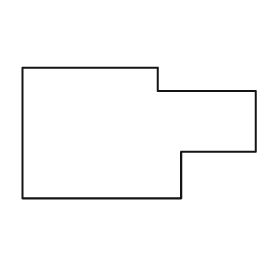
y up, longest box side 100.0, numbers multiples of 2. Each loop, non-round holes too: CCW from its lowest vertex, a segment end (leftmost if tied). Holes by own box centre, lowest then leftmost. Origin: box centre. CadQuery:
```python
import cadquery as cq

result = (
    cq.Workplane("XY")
    .moveTo(-50.0, -28.0)
    .lineTo(18.0, -28.0)
    .lineTo(18.0, -8.0)
    .lineTo(50.0, -8.0)
    .lineTo(50.0, 18.0)
    .lineTo(8.0, 18.0)
    .lineTo(8.0, 28.0)
    .lineTo(-50.0, 28.0)
    .close()
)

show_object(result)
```